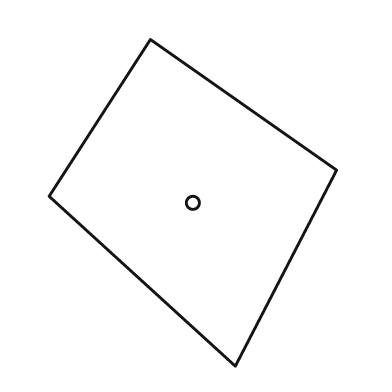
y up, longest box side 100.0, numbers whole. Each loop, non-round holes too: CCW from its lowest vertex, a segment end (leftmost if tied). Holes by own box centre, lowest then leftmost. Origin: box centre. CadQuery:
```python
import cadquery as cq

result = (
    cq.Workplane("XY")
    .moveTo(13.0, -50.0)
    .lineTo(44.0, 10.0)
    .lineTo(-13.0, 50.0)
    .lineTo(-44.0, 2.0)
    .close()
    .moveTo(0.0, 0.0)
    .circle(2.0)
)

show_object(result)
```